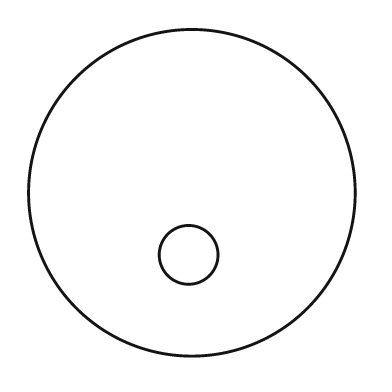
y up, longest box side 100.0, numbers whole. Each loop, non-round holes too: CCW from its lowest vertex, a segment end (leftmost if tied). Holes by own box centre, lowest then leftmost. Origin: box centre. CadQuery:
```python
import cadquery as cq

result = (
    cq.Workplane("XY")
    .moveTo(0.0, 0.0)
    .circle(50.0)
    .moveTo(-1.0, -19.0)
    .circle(9.0)
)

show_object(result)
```